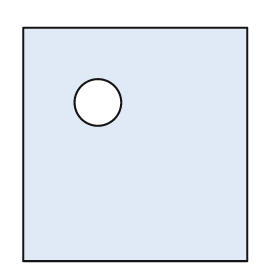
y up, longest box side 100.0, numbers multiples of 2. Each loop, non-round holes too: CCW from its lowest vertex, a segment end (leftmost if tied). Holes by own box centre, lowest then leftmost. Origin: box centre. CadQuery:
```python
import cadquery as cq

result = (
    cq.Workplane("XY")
    .moveTo(-48.0, -50.0)
    .lineTo(48.0, -50.0)
    .lineTo(48.0, 50.0)
    .lineTo(-48.0, 50.0)
    .close()
    .moveTo(-16.0, 18.0)
    .circle(10.0)
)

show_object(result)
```